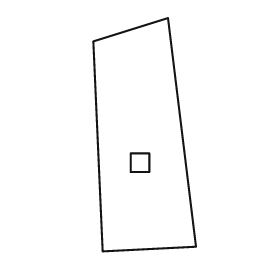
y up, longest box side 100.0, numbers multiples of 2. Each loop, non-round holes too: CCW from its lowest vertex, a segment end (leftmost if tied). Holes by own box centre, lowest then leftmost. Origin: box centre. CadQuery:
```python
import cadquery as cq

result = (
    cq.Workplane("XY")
    .moveTo(-18.0, -50.0)
    .lineTo(22.0, -48.0)
    .lineTo(10.0, 50.0)
    .lineTo(-22.0, 40.0)
    .close()
    .moveTo(-6.0, -16.0)
    .lineTo(2.0, -16.0)
    .lineTo(2.0, -8.0)
    .lineTo(-6.0, -8.0)
    .close()
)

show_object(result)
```